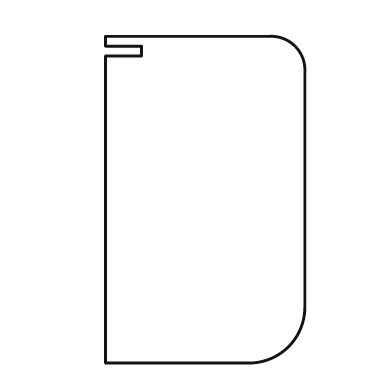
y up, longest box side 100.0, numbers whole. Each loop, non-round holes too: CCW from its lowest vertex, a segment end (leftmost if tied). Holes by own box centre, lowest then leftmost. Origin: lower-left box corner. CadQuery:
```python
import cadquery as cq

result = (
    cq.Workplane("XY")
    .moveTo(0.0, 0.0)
    .lineTo(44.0, 0.0)
    .threePointArc((56.0, 5.0), (61.0, 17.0))
    .lineTo(61.0, 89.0)
    .threePointArc((58.0, 97.0), (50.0, 100.0))
    .lineTo(0.0, 100.0)
    .lineTo(0.0, 97.0)
    .lineTo(11.0, 97.0)
    .lineTo(11.0, 94.0)
    .lineTo(0.0, 94.0)
    .close()
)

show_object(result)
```